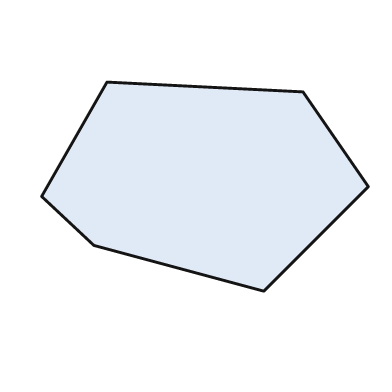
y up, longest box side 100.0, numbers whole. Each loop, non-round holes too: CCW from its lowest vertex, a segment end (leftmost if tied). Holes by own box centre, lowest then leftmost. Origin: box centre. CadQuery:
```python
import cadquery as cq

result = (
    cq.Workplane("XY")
    .moveTo(18.0, -32.0)
    .lineTo(50.0, 0.0)
    .lineTo(30.0, 29.0)
    .lineTo(-30.0, 32.0)
    .lineTo(-50.0, -3.0)
    .lineTo(-34.0, -18.0)
    .close()
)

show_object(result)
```